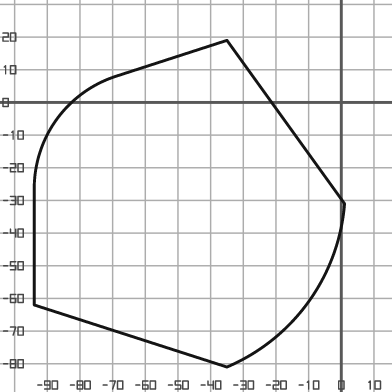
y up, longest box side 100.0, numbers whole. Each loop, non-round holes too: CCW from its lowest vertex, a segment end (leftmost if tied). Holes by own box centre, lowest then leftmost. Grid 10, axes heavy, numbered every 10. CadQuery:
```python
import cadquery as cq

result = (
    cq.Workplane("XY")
    .moveTo(-35.0, -81.0)
    .threePointArc((-10.0, -61.0), (1.0, -31.0))
    .lineTo(-35.0, 19.0)
    .lineTo(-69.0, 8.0)
    .threePointArc((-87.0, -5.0), (-94.0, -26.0))
    .lineTo(-94.0, -62.0)
    .close()
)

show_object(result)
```